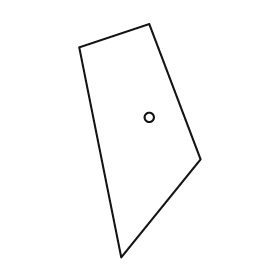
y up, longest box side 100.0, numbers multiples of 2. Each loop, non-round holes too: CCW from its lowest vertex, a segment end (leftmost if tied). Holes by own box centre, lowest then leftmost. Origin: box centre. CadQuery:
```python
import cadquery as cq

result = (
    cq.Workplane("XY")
    .moveTo(-8.0, -50.0)
    .lineTo(26.0, -8.0)
    .lineTo(4.0, 50.0)
    .lineTo(-26.0, 40.0)
    .close()
    .moveTo(4.0, 10.0)
    .circle(2.0)
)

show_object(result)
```